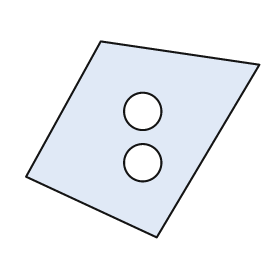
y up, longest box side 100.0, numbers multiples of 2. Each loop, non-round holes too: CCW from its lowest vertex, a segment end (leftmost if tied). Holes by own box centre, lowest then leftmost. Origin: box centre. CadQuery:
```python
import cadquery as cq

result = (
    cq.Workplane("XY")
    .moveTo(6.0, -42.0)
    .lineTo(50.0, 32.0)
    .lineTo(-18.0, 42.0)
    .lineTo(-50.0, -16.0)
    .close()
    .moveTo(0.0, -10.0)
    .circle(8.0)
    .moveTo(0.0, 12.0)
    .circle(8.0)
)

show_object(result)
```